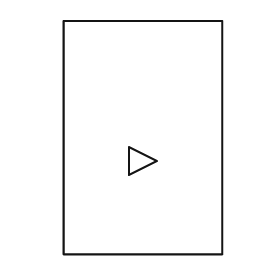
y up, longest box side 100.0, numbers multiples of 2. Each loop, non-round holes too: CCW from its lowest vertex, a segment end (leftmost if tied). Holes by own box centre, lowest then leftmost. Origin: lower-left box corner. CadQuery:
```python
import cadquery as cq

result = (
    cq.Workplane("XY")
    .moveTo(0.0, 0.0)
    .lineTo(68.0, 0.0)
    .lineTo(68.0, 100.0)
    .lineTo(0.0, 100.0)
    .close()
    .moveTo(28.0, 34.0)
    .lineTo(40.0, 40.0)
    .lineTo(28.0, 46.0)
    .close()
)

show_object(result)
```